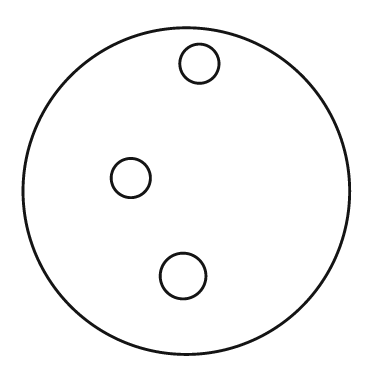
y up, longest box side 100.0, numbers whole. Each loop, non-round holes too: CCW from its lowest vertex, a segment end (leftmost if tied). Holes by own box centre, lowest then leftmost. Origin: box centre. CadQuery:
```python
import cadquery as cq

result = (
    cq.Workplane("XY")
    .moveTo(0.0, 0.0)
    .circle(50.0)
    .moveTo(-1.0, -26.0)
    .circle(7.0)
    .moveTo(-17.0, 4.0)
    .circle(6.0)
    .moveTo(4.0, 39.0)
    .circle(6.0)
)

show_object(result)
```